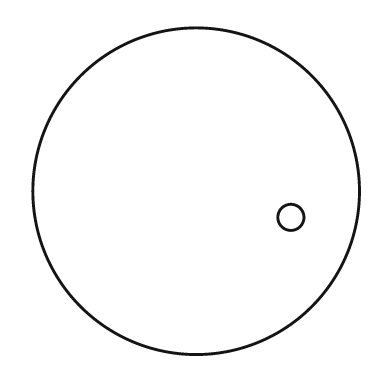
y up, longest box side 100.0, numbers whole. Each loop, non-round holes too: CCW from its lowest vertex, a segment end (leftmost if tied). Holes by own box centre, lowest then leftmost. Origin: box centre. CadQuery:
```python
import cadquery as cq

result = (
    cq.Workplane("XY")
    .moveTo(0.0, 0.0)
    .circle(50.0)
    .moveTo(29.0, -8.0)
    .circle(4.0)
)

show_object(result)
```